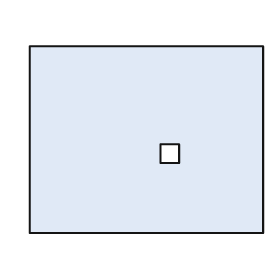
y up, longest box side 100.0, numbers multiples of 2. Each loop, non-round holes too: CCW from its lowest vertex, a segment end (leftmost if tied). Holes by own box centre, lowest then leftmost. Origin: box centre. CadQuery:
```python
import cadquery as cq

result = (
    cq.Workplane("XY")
    .moveTo(-50.0, -40.0)
    .lineTo(50.0, -40.0)
    .lineTo(50.0, 40.0)
    .lineTo(-50.0, 40.0)
    .close()
    .moveTo(6.0, -10.0)
    .lineTo(14.0, -10.0)
    .lineTo(14.0, -2.0)
    .lineTo(6.0, -2.0)
    .close()
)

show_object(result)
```